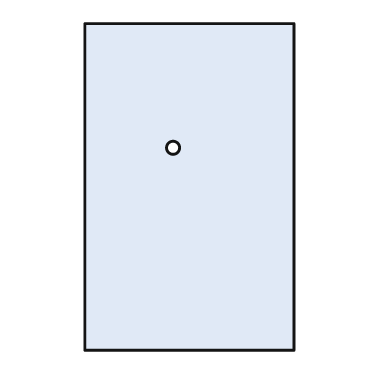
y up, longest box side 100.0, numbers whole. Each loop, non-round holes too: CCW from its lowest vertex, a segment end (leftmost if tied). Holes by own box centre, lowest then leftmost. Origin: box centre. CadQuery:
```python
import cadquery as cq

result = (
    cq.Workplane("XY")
    .moveTo(-32.0, -50.0)
    .lineTo(32.0, -50.0)
    .lineTo(32.0, 50.0)
    .lineTo(-32.0, 50.0)
    .close()
    .moveTo(-5.0, 12.0)
    .circle(2.0)
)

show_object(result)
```